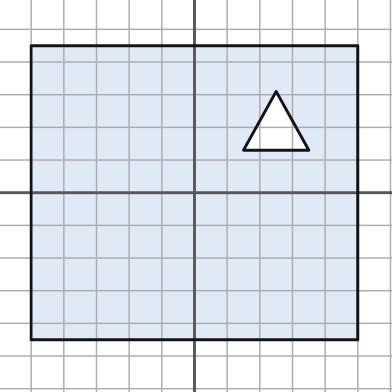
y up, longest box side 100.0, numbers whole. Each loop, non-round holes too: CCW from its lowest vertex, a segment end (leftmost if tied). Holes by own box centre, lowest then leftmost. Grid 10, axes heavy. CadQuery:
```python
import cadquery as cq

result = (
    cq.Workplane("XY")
    .moveTo(-50.0, -45.0)
    .lineTo(50.0, -45.0)
    .lineTo(50.0, 45.0)
    .lineTo(-50.0, 45.0)
    .close()
    .moveTo(15.0, 13.0)
    .lineTo(35.0, 13.0)
    .lineTo(25.0, 31.0)
    .close()
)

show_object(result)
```